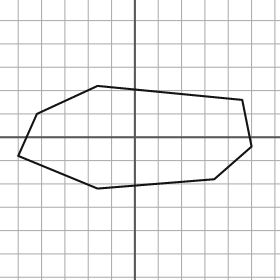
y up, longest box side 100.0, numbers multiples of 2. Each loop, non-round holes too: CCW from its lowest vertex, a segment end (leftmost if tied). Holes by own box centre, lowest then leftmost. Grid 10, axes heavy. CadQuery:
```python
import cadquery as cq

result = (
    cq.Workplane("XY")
    .moveTo(-16.0, -22.0)
    .lineTo(34.0, -18.0)
    .lineTo(50.0, -4.0)
    .lineTo(46.0, 16.0)
    .lineTo(-16.0, 22.0)
    .lineTo(-42.0, 10.0)
    .lineTo(-50.0, -8.0)
    .close()
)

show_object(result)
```